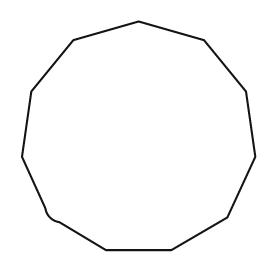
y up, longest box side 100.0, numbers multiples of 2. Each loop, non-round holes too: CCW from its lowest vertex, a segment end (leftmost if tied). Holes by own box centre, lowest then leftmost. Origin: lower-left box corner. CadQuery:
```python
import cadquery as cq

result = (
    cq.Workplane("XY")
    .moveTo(36.0, 0.0)
    .lineTo(64.0, 0.0)
    .lineTo(88.0, 14.0)
    .lineTo(100.0, 40.0)
    .lineTo(96.0, 68.0)
    .lineTo(78.0, 90.0)
    .lineTo(50.0, 98.0)
    .lineTo(22.0, 90.0)
    .lineTo(4.0, 68.0)
    .lineTo(0.0, 40.0)
    .lineTo(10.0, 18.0)
    .threePointArc((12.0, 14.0), (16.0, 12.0))
    .close()
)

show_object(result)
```